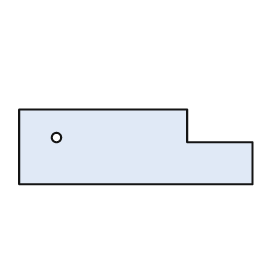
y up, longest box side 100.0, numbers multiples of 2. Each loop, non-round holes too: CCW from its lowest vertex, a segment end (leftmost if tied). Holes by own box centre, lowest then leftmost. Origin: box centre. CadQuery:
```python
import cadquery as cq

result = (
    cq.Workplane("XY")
    .moveTo(-50.0, -16.0)
    .lineTo(50.0, -16.0)
    .lineTo(50.0, 2.0)
    .lineTo(22.0, 2.0)
    .lineTo(22.0, 16.0)
    .lineTo(-50.0, 16.0)
    .close()
    .moveTo(-34.0, 4.0)
    .circle(2.0)
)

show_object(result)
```